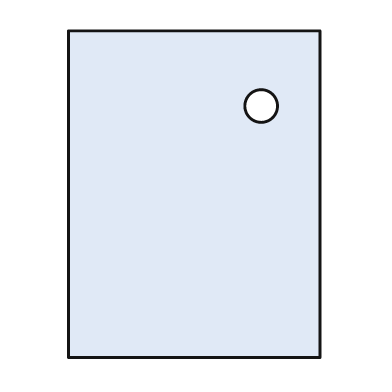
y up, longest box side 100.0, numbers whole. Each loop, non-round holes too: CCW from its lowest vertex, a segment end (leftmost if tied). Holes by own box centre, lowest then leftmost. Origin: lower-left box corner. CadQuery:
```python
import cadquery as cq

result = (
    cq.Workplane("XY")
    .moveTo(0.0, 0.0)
    .lineTo(77.0, 0.0)
    .lineTo(77.0, 100.0)
    .lineTo(0.0, 100.0)
    .close()
    .moveTo(59.0, 77.0)
    .circle(5.0)
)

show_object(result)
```